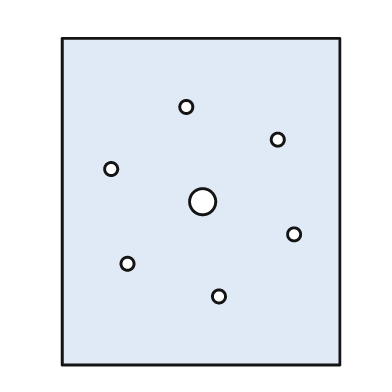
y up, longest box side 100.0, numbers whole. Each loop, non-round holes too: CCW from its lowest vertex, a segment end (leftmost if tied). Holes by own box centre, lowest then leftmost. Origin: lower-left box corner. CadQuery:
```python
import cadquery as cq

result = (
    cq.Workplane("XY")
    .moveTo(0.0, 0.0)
    .lineTo(85.0, 0.0)
    .lineTo(85.0, 100.0)
    .lineTo(0.0, 100.0)
    .close()
    .moveTo(48.0, 21.0)
    .circle(2.0)
    .moveTo(20.0, 31.0)
    .circle(2.0)
    .moveTo(71.0, 40.0)
    .circle(2.0)
    .moveTo(43.0, 50.0)
    .circle(4.0)
    .moveTo(15.0, 60.0)
    .circle(2.0)
    .moveTo(66.0, 69.0)
    .circle(2.0)
    .moveTo(38.0, 79.0)
    .circle(2.0)
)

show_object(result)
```